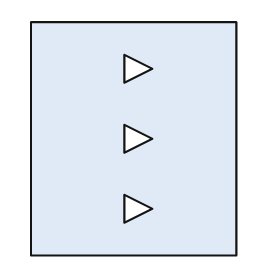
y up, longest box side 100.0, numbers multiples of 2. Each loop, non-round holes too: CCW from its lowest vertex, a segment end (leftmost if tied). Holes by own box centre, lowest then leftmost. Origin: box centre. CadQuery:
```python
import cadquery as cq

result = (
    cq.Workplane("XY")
    .moveTo(-44.0, -50.0)
    .lineTo(44.0, -50.0)
    .lineTo(44.0, 50.0)
    .lineTo(-44.0, 50.0)
    .close()
    .moveTo(-4.0, -36.0)
    .lineTo(8.0, -30.0)
    .lineTo(-4.0, -24.0)
    .close()
    .moveTo(-4.0, -6.0)
    .lineTo(8.0, 0.0)
    .lineTo(-4.0, 6.0)
    .close()
    .moveTo(-4.0, 24.0)
    .lineTo(8.0, 30.0)
    .lineTo(-4.0, 36.0)
    .close()
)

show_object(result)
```